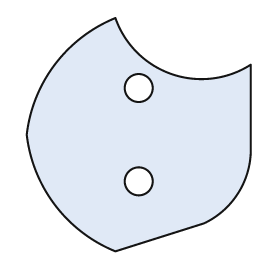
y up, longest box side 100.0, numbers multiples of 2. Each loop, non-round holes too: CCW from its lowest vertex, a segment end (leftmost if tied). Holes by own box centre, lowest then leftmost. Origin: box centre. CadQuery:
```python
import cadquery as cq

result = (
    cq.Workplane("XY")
    .moveTo(-10.0, -50.0)
    .lineTo(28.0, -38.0)
    .threePointArc((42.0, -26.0), (48.0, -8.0))
    .lineTo(48.0, 30.0)
    .threePointArc((14.0, 26.0), (-10.0, 50.0))
    .threePointArc((-36.0, 30.0), (-48.0, 0.0))
    .threePointArc((-36.0, -30.0), (-10.0, -50.0))
    .close()
    .moveTo(0.0, -20.0)
    .circle(6.0)
    .moveTo(0.0, 20.0)
    .circle(6.0)
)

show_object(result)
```